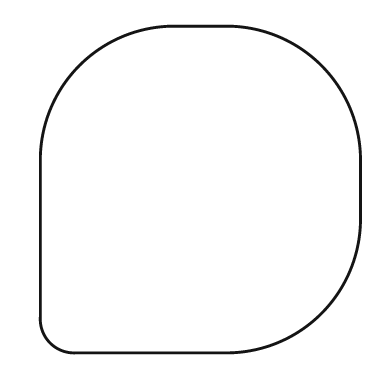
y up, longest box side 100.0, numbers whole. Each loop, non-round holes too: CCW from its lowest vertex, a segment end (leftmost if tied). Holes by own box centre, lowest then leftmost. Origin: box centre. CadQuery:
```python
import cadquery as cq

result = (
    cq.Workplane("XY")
    .moveTo(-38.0, -50.0)
    .lineTo(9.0, -50.0)
    .threePointArc((37.0, -38.0), (49.0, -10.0))
    .lineTo(49.0, 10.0)
    .threePointArc((37.0, 38.0), (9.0, 50.0))
    .lineTo(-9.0, 50.0)
    .threePointArc((-37.0, 38.0), (-49.0, 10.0))
    .lineTo(-49.0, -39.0)
    .threePointArc((-46.0, -47.0), (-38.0, -50.0))
    .close()
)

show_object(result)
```